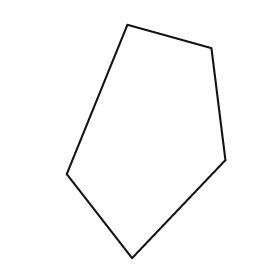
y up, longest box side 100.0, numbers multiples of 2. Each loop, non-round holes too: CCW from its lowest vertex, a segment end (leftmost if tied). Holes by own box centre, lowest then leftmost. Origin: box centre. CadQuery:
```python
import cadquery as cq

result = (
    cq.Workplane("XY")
    .moveTo(-6.0, -50.0)
    .lineTo(34.0, -8.0)
    .lineTo(28.0, 40.0)
    .lineTo(-8.0, 50.0)
    .lineTo(-34.0, -14.0)
    .close()
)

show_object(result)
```